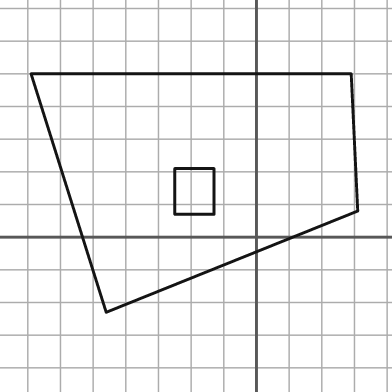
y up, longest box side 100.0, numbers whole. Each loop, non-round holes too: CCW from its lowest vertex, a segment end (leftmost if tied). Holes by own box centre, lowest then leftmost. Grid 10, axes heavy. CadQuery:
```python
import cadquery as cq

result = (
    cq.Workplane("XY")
    .moveTo(-46.0, -23.0)
    .lineTo(31.0, 8.0)
    .lineTo(29.0, 50.0)
    .lineTo(-69.0, 50.0)
    .close()
    .moveTo(-25.0, 7.0)
    .lineTo(-13.0, 7.0)
    .lineTo(-13.0, 21.0)
    .lineTo(-25.0, 21.0)
    .close()
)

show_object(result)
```